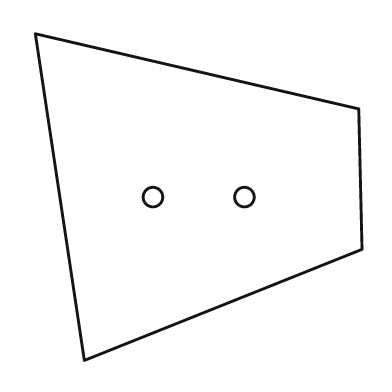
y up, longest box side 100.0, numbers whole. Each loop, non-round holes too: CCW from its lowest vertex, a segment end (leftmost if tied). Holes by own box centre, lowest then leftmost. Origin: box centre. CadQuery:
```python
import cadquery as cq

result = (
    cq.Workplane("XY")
    .moveTo(-35.0, -50.0)
    .lineTo(50.0, -16.0)
    .lineTo(49.0, 27.0)
    .lineTo(-50.0, 50.0)
    .close()
    .moveTo(-14.0, 0.0)
    .circle(3.0)
    .moveTo(14.0, 0.0)
    .circle(3.0)
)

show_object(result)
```